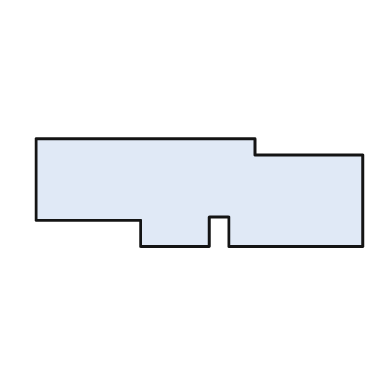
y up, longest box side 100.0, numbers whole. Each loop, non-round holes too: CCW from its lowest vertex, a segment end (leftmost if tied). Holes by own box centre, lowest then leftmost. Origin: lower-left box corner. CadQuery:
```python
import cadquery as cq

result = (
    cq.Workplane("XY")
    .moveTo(32.0, 0.0)
    .lineTo(53.0, 0.0)
    .lineTo(53.0, 9.0)
    .lineTo(59.0, 9.0)
    .lineTo(59.0, 0.0)
    .lineTo(100.0, 0.0)
    .lineTo(100.0, 28.0)
    .lineTo(67.0, 28.0)
    .lineTo(67.0, 33.0)
    .lineTo(0.0, 33.0)
    .lineTo(0.0, 8.0)
    .lineTo(32.0, 8.0)
    .close()
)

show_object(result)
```